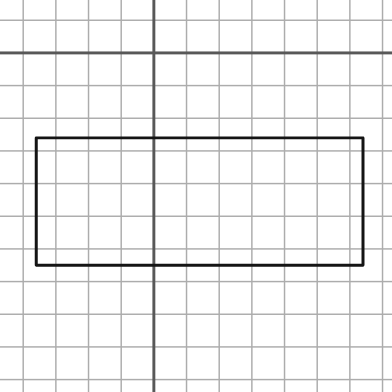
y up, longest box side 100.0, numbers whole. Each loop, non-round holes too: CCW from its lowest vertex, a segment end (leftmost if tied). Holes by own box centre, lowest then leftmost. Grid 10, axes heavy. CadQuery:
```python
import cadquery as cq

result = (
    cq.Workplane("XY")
    .moveTo(-36.0, -65.0)
    .lineTo(64.0, -65.0)
    .lineTo(64.0, -26.0)
    .lineTo(-36.0, -26.0)
    .close()
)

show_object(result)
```